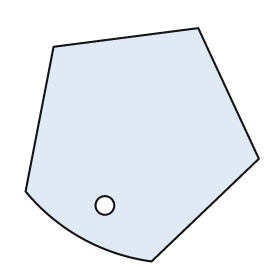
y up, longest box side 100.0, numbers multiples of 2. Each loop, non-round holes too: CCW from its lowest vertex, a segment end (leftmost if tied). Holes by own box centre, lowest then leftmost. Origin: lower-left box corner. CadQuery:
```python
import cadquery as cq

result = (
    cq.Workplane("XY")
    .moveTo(54.0, 0.0)
    .lineTo(100.0, 44.0)
    .lineTo(74.0, 100.0)
    .lineTo(12.0, 92.0)
    .lineTo(0.0, 30.0)
    .threePointArc((24.0, 10.0), (54.0, 0.0))
    .close()
    .moveTo(34.0, 24.0)
    .circle(4.0)
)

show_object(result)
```